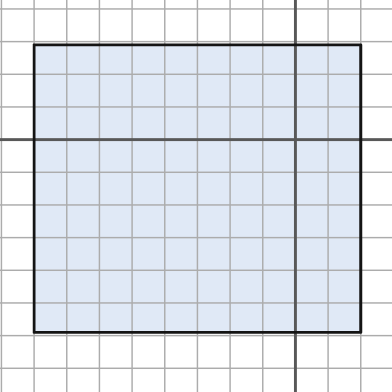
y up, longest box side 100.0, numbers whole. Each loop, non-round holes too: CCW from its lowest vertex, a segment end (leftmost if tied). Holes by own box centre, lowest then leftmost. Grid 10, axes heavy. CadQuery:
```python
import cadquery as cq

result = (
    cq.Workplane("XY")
    .moveTo(-80.0, -59.0)
    .lineTo(20.0, -59.0)
    .lineTo(20.0, 29.0)
    .lineTo(-80.0, 29.0)
    .close()
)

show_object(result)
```